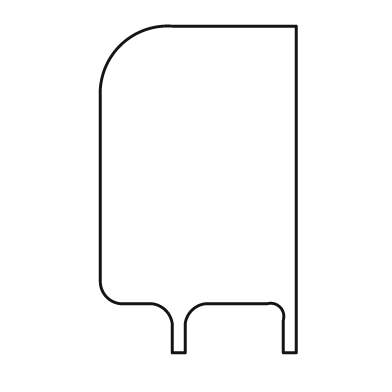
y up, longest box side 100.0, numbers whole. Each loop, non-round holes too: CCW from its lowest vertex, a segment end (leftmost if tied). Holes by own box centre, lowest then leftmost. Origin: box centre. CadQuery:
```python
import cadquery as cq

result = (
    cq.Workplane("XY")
    .moveTo(-8.0, -50.0)
    .lineTo(-4.0, -50.0)
    .lineTo(-4.0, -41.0)
    .threePointArc((-2.0, -37.0), (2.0, -35.0))
    .lineTo(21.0, -35.0)
    .threePointArc((25.0, -36.0), (26.0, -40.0))
    .lineTo(26.0, -50.0)
    .lineTo(30.0, -50.0)
    .lineTo(30.0, 50.0)
    .lineTo(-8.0, 50.0)
    .threePointArc((-24.0, 44.0), (-30.0, 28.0))
    .lineTo(-30.0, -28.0)
    .threePointArc((-28.0, -33.0), (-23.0, -35.0))
    .lineTo(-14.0, -35.0)
    .threePointArc((-10.0, -37.0), (-8.0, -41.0))
    .close()
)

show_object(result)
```